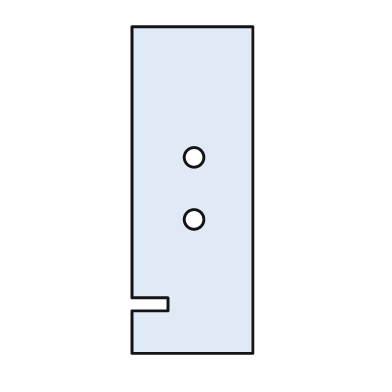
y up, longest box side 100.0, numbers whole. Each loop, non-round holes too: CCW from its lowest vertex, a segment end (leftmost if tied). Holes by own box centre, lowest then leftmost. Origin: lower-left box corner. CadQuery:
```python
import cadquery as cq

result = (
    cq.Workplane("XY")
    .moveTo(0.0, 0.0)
    .lineTo(37.0, 0.0)
    .lineTo(37.0, 100.0)
    .lineTo(0.0, 100.0)
    .lineTo(0.0, 17.0)
    .lineTo(11.0, 17.0)
    .lineTo(11.0, 13.0)
    .lineTo(0.0, 13.0)
    .close()
    .moveTo(19.0, 41.0)
    .circle(3.0)
    .moveTo(19.0, 60.0)
    .circle(3.0)
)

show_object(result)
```